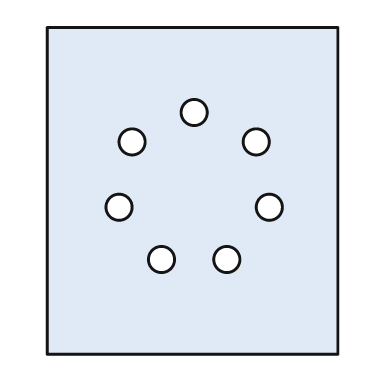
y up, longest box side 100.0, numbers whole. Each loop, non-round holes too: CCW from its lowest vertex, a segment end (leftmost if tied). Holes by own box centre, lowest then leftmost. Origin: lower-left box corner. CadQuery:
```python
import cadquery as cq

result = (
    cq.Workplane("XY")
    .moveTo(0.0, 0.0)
    .lineTo(89.0, 0.0)
    .lineTo(89.0, 100.0)
    .lineTo(0.0, 100.0)
    .close()
    .moveTo(35.0, 29.0)
    .circle(4.0)
    .moveTo(55.0, 29.0)
    .circle(4.0)
    .moveTo(22.0, 45.0)
    .circle(4.0)
    .moveTo(68.0, 45.0)
    .circle(4.0)
    .moveTo(26.0, 65.0)
    .circle(4.0)
    .moveTo(64.0, 65.0)
    .circle(4.0)
    .moveTo(45.0, 74.0)
    .circle(4.0)
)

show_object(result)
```